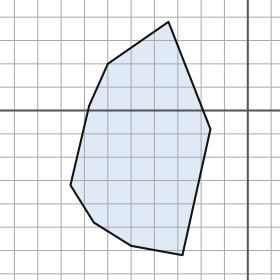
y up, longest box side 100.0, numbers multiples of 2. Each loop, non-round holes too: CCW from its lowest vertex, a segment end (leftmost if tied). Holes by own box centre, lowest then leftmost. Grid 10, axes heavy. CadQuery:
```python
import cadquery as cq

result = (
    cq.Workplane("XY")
    .moveTo(-28.0, -62.0)
    .lineTo(-16.0, -8.0)
    .lineTo(-34.0, 38.0)
    .lineTo(-60.0, 20.0)
    .lineTo(-68.0, 2.0)
    .lineTo(-76.0, -32.0)
    .lineTo(-66.0, -48.0)
    .lineTo(-50.0, -58.0)
    .close()
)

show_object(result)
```